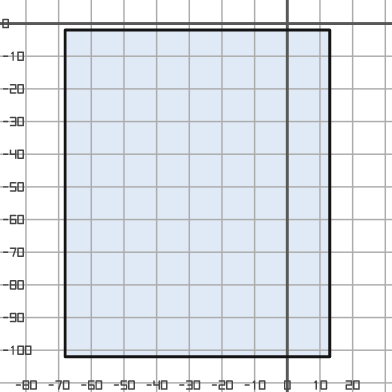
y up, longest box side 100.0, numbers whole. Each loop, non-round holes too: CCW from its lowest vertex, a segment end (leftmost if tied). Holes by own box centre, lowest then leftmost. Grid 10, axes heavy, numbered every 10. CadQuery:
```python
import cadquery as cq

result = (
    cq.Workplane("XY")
    .moveTo(-68.0, -102.0)
    .lineTo(13.0, -102.0)
    .lineTo(13.0, -2.0)
    .lineTo(-68.0, -2.0)
    .close()
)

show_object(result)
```